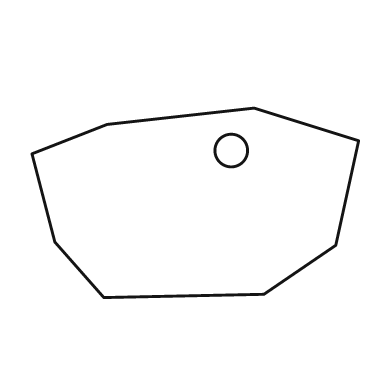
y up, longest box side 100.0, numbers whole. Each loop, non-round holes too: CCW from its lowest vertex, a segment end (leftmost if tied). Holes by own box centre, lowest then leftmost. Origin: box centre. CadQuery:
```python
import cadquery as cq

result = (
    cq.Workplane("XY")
    .moveTo(-28.0, -29.0)
    .lineTo(21.0, -28.0)
    .lineTo(43.0, -13.0)
    .lineTo(50.0, 19.0)
    .lineTo(18.0, 29.0)
    .lineTo(-27.0, 24.0)
    .lineTo(-50.0, 15.0)
    .lineTo(-43.0, -12.0)
    .close()
    .moveTo(11.0, 16.0)
    .circle(5.0)
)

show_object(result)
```